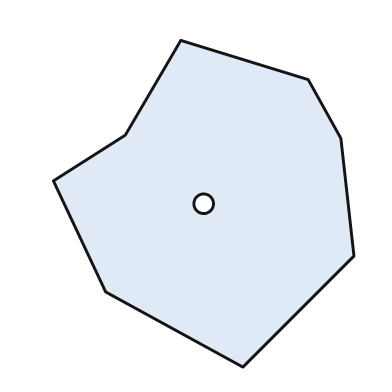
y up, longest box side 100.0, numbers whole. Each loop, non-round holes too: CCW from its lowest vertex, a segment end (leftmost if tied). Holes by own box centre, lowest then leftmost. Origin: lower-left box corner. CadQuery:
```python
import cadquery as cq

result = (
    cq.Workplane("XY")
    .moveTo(58.0, 0.0)
    .lineTo(92.0, 34.0)
    .lineTo(88.0, 70.0)
    .lineTo(78.0, 88.0)
    .lineTo(39.0, 100.0)
    .lineTo(22.0, 71.0)
    .lineTo(0.0, 57.0)
    .lineTo(16.0, 23.0)
    .close()
    .moveTo(46.0, 50.0)
    .circle(3.0)
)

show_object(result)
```